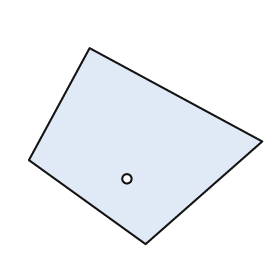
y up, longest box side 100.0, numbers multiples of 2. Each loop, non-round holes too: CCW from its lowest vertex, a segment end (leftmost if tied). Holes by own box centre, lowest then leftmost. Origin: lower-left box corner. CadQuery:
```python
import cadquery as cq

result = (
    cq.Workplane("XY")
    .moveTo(50.0, 0.0)
    .lineTo(100.0, 44.0)
    .lineTo(26.0, 84.0)
    .lineTo(0.0, 36.0)
    .close()
    .moveTo(42.0, 28.0)
    .circle(2.0)
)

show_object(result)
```